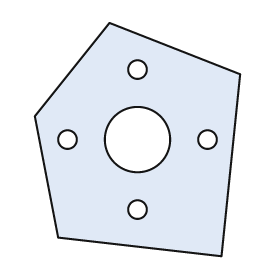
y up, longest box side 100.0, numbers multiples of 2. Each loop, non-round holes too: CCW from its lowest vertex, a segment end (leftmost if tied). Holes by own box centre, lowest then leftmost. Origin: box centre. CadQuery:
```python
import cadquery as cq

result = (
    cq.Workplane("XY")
    .moveTo(36.0, -50.0)
    .lineTo(44.0, 28.0)
    .lineTo(-12.0, 50.0)
    .lineTo(-44.0, 10.0)
    .lineTo(-34.0, -42.0)
    .close()
    .moveTo(0.0, -30.0)
    .circle(4.0)
    .moveTo(-30.0, 0.0)
    .circle(4.0)
    .moveTo(0.0, 0.0)
    .circle(14.0)
    .moveTo(30.0, 0.0)
    .circle(4.0)
    .moveTo(0.0, 30.0)
    .circle(4.0)
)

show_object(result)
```